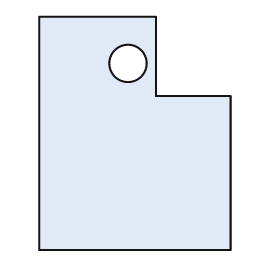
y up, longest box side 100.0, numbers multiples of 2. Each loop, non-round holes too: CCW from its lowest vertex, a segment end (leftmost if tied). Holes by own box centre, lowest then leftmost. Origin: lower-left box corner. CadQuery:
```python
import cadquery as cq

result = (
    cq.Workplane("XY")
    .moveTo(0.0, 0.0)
    .lineTo(82.0, 0.0)
    .lineTo(82.0, 66.0)
    .lineTo(50.0, 66.0)
    .lineTo(50.0, 100.0)
    .lineTo(0.0, 100.0)
    .close()
    .moveTo(38.0, 80.0)
    .circle(8.0)
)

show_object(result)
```